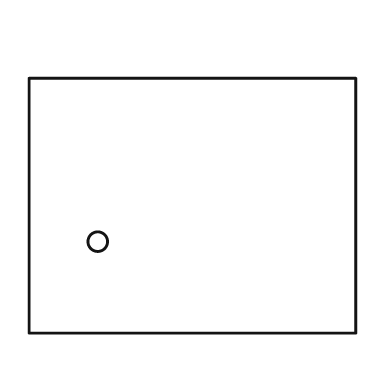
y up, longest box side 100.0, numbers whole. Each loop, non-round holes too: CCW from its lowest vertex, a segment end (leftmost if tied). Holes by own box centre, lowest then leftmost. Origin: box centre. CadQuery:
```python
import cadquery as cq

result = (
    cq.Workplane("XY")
    .moveTo(-50.0, -39.0)
    .lineTo(50.0, -39.0)
    .lineTo(50.0, 39.0)
    .lineTo(-50.0, 39.0)
    .close()
    .moveTo(-29.0, -11.0)
    .circle(3.0)
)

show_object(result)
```